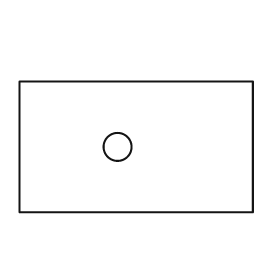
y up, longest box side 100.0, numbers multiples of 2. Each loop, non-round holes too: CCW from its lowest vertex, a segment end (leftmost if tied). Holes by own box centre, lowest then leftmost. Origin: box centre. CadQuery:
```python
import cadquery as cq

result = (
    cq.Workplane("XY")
    .moveTo(-50.0, -28.0)
    .lineTo(50.0, -28.0)
    .lineTo(50.0, 28.0)
    .lineTo(-50.0, 28.0)
    .close()
    .moveTo(-8.0, 0.0)
    .circle(6.0)
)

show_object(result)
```